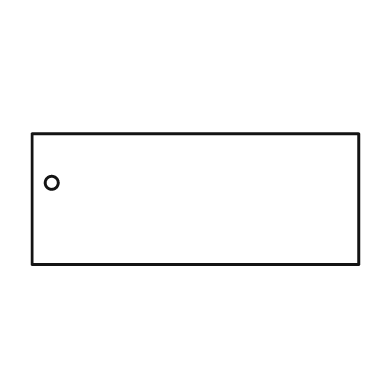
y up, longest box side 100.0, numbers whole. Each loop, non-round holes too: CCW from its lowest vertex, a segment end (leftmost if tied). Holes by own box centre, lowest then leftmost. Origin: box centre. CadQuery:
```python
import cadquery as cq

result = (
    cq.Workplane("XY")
    .moveTo(-50.0, -20.0)
    .lineTo(50.0, -20.0)
    .lineTo(50.0, 20.0)
    .lineTo(-50.0, 20.0)
    .close()
    .moveTo(-44.0, 5.0)
    .circle(2.0)
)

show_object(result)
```